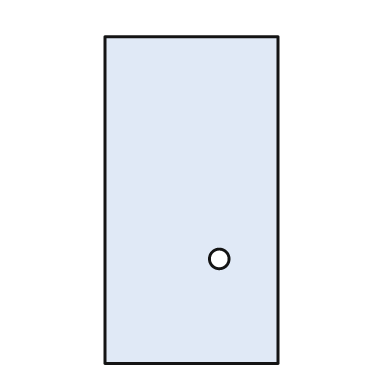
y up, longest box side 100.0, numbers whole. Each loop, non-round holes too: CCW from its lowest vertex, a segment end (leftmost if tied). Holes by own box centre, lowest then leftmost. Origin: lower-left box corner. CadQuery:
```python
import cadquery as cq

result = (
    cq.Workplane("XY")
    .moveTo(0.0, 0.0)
    .lineTo(53.0, 0.0)
    .lineTo(53.0, 100.0)
    .lineTo(0.0, 100.0)
    .close()
    .moveTo(35.0, 32.0)
    .circle(3.0)
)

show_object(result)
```